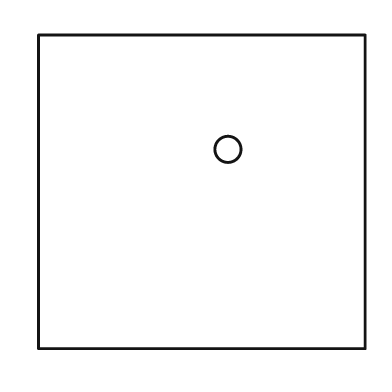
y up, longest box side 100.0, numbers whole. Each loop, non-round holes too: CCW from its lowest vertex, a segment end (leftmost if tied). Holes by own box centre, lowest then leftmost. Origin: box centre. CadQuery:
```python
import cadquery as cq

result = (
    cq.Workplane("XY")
    .moveTo(-50.0, -48.0)
    .lineTo(50.0, -48.0)
    .lineTo(50.0, 48.0)
    .lineTo(-50.0, 48.0)
    .close()
    .moveTo(8.0, 13.0)
    .circle(4.0)
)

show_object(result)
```